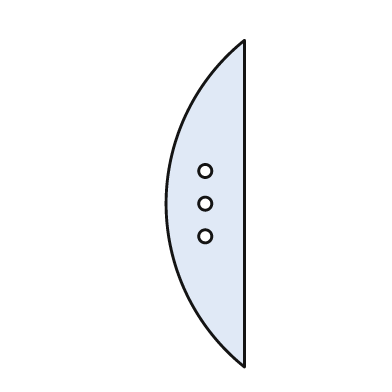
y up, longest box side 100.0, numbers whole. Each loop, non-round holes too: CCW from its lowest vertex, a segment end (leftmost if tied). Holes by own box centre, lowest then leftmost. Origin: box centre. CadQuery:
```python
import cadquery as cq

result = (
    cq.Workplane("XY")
    .moveTo(12.0, -50.0)
    .lineTo(12.0, 50.0)
    .threePointArc((-12.0, 0.0), (12.0, -50.0))
    .close()
    .moveTo(0.0, -10.0)
    .circle(2.0)
    .moveTo(0.0, 0.0)
    .circle(2.0)
    .moveTo(0.0, 10.0)
    .circle(2.0)
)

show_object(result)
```